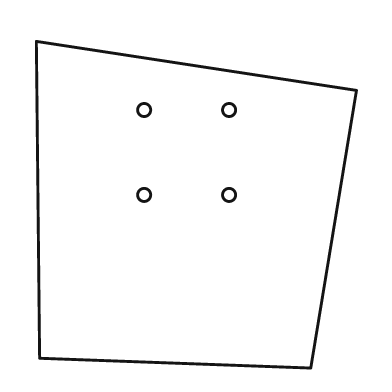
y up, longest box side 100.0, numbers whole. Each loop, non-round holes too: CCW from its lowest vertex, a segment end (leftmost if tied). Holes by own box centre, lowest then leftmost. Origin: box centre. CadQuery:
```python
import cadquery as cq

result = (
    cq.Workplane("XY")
    .moveTo(35.0, -50.0)
    .lineTo(49.0, 35.0)
    .lineTo(-49.0, 50.0)
    .lineTo(-48.0, -47.0)
    .close()
    .moveTo(-16.0, 3.0)
    .circle(2.0)
    .moveTo(10.0, 3.0)
    .circle(2.0)
    .moveTo(-16.0, 29.0)
    .circle(2.0)
    .moveTo(10.0, 29.0)
    .circle(2.0)
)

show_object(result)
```